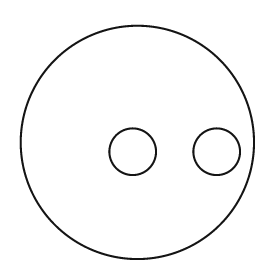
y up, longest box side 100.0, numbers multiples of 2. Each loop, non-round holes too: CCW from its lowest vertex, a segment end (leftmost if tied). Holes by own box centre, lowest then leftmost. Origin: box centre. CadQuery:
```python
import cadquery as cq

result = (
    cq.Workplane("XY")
    .moveTo(0.0, 0.0)
    .circle(50.0)
    .moveTo(-2.0, -4.0)
    .circle(10.0)
    .moveTo(34.0, -4.0)
    .circle(10.0)
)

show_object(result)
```